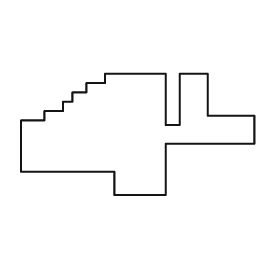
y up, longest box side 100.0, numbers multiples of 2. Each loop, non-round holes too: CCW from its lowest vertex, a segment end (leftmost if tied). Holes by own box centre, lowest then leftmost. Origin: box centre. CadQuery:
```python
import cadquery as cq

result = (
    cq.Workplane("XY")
    .moveTo(-10.0, -26.0)
    .lineTo(12.0, -26.0)
    .lineTo(12.0, -4.0)
    .lineTo(50.0, -4.0)
    .lineTo(50.0, 8.0)
    .lineTo(30.0, 8.0)
    .lineTo(30.0, 26.0)
    .lineTo(18.0, 26.0)
    .lineTo(18.0, 4.0)
    .lineTo(12.0, 4.0)
    .lineTo(12.0, 26.0)
    .lineTo(-14.0, 26.0)
    .lineTo(-14.0, 22.0)
    .lineTo(-22.0, 22.0)
    .lineTo(-22.0, 18.0)
    .lineTo(-28.0, 18.0)
    .lineTo(-28.0, 14.0)
    .lineTo(-32.0, 14.0)
    .lineTo(-32.0, 10.0)
    .lineTo(-40.0, 10.0)
    .lineTo(-40.0, 6.0)
    .lineTo(-50.0, 6.0)
    .lineTo(-50.0, -16.0)
    .lineTo(-10.0, -16.0)
    .close()
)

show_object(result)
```